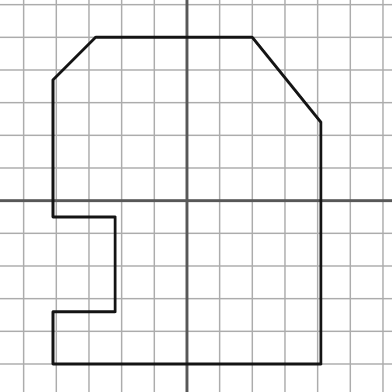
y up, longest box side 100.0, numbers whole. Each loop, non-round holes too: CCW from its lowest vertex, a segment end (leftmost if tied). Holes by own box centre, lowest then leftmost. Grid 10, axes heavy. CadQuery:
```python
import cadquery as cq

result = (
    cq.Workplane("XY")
    .moveTo(-41.0, -50.0)
    .lineTo(41.0, -50.0)
    .lineTo(41.0, 24.0)
    .lineTo(20.0, 50.0)
    .lineTo(-28.0, 50.0)
    .lineTo(-41.0, 37.0)
    .lineTo(-41.0, -5.0)
    .lineTo(-22.0, -5.0)
    .lineTo(-22.0, -34.0)
    .lineTo(-41.0, -34.0)
    .close()
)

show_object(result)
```